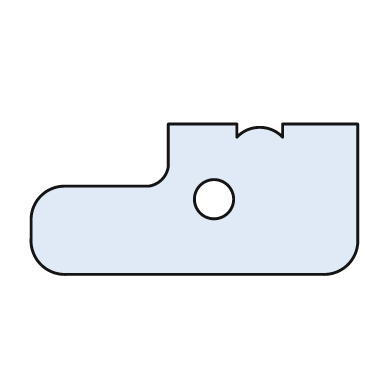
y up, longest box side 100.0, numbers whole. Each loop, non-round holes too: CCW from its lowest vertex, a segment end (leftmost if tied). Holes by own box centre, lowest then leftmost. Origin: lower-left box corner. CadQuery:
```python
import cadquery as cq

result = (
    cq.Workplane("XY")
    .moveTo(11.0, 0.0)
    .lineTo(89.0, 0.0)
    .threePointArc((97.0, 3.0), (100.0, 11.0))
    .lineTo(100.0, 46.0)
    .lineTo(77.0, 46.0)
    .lineTo(77.0, 42.0)
    .threePointArc((70.0, 45.0), (63.0, 42.0))
    .lineTo(63.0, 46.0)
    .lineTo(42.0, 46.0)
    .lineTo(42.0, 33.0)
    .threePointArc((40.0, 29.0), (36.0, 27.0))
    .lineTo(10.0, 27.0)
    .threePointArc((3.0, 24.0), (0.0, 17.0))
    .lineTo(0.0, 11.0)
    .threePointArc((3.0, 3.0), (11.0, 0.0))
    .close()
    .moveTo(56.0, 23.0)
    .circle(6.0)
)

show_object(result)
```